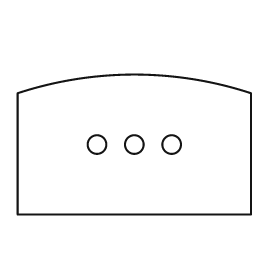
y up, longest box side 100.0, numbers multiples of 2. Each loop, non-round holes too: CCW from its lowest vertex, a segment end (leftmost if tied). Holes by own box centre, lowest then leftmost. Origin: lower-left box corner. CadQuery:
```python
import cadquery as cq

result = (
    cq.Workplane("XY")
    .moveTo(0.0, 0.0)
    .lineTo(100.0, 0.0)
    .lineTo(100.0, 52.0)
    .threePointArc((50.0, 60.0), (0.0, 52.0))
    .close()
    .moveTo(34.0, 30.0)
    .circle(4.0)
    .moveTo(50.0, 30.0)
    .circle(4.0)
    .moveTo(66.0, 30.0)
    .circle(4.0)
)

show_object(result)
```